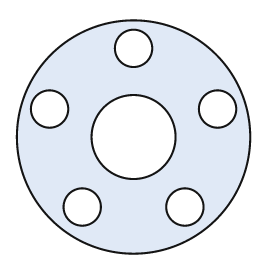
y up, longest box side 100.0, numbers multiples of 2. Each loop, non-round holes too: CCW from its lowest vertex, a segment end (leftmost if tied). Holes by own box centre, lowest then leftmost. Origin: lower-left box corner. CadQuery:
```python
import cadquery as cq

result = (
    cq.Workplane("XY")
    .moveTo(50.0, 50.0)
    .circle(50.0)
    .moveTo(28.0, 20.0)
    .circle(8.0)
    .moveTo(72.0, 20.0)
    .circle(8.0)
    .moveTo(50.0, 50.0)
    .circle(18.0)
    .moveTo(14.0, 62.0)
    .circle(8.0)
    .moveTo(86.0, 62.0)
    .circle(8.0)
    .moveTo(50.0, 88.0)
    .circle(8.0)
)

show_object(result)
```